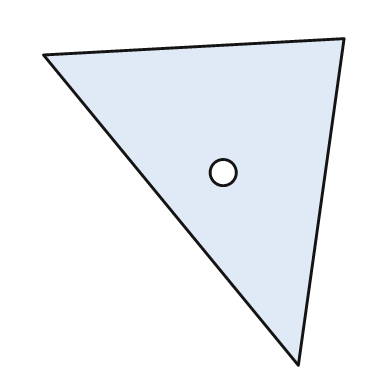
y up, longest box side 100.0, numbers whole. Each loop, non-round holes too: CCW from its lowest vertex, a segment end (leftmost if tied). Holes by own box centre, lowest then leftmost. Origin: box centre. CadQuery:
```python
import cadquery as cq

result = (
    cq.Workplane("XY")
    .moveTo(32.0, -50.0)
    .lineTo(46.0, 50.0)
    .lineTo(-46.0, 45.0)
    .close()
    .moveTo(9.0, 9.0)
    .circle(4.0)
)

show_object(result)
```